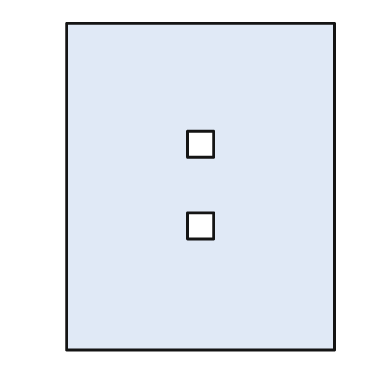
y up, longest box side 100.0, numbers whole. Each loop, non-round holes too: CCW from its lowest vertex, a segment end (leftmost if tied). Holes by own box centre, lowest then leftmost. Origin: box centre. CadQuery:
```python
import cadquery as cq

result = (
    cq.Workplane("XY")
    .moveTo(-41.0, -50.0)
    .lineTo(41.0, -50.0)
    .lineTo(41.0, 50.0)
    .lineTo(-41.0, 50.0)
    .close()
    .moveTo(-4.0, -16.0)
    .lineTo(4.0, -16.0)
    .lineTo(4.0, -8.0)
    .lineTo(-4.0, -8.0)
    .close()
    .moveTo(-4.0, 9.0)
    .lineTo(4.0, 9.0)
    .lineTo(4.0, 17.0)
    .lineTo(-4.0, 17.0)
    .close()
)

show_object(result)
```